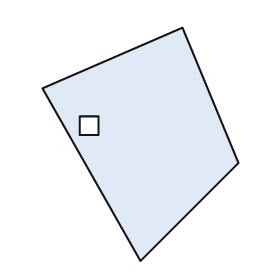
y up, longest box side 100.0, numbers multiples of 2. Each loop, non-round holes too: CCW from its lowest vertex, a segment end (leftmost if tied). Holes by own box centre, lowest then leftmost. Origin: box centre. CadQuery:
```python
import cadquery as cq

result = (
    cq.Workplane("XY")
    .moveTo(0.0, -50.0)
    .lineTo(42.0, -8.0)
    .lineTo(18.0, 50.0)
    .lineTo(-42.0, 24.0)
    .close()
    .moveTo(-26.0, 4.0)
    .lineTo(-18.0, 4.0)
    .lineTo(-18.0, 12.0)
    .lineTo(-26.0, 12.0)
    .close()
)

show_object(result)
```